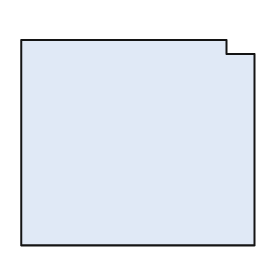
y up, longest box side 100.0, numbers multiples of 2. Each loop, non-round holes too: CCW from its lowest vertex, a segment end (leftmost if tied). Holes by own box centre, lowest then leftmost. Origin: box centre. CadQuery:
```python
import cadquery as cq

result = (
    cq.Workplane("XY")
    .moveTo(-50.0, -44.0)
    .lineTo(50.0, -44.0)
    .lineTo(50.0, 38.0)
    .lineTo(38.0, 38.0)
    .lineTo(38.0, 44.0)
    .lineTo(-50.0, 44.0)
    .close()
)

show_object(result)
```